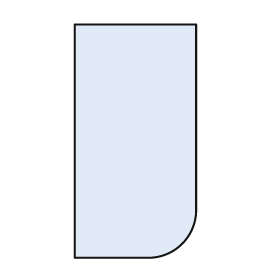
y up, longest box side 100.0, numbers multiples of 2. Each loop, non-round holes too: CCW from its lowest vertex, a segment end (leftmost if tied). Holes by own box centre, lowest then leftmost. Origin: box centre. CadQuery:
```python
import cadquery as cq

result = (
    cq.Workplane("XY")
    .moveTo(-26.0, -50.0)
    .lineTo(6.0, -50.0)
    .threePointArc((20.0, -44.0), (26.0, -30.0))
    .lineTo(26.0, 50.0)
    .lineTo(-26.0, 50.0)
    .close()
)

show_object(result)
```